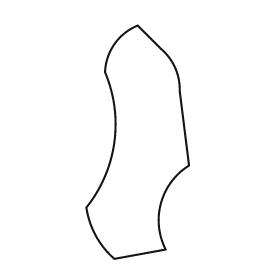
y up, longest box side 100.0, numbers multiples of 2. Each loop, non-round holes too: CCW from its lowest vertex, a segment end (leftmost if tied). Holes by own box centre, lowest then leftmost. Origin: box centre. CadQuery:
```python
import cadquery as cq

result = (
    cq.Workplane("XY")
    .moveTo(-10.0, -50.0)
    .lineTo(12.0, -46.0)
    .threePointArc((10.0, -26.0), (22.0, -10.0))
    .lineTo(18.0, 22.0)
    .threePointArc((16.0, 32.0), (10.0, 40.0))
    .lineTo(0.0, 50.0)
    .threePointArc((-10.0, 42.0), (-14.0, 30.0))
    .threePointArc((-10.0, 0.0), (-22.0, -28.0))
    .threePointArc((-18.0, -40.0), (-10.0, -50.0))
    .close()
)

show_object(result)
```